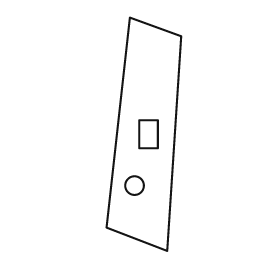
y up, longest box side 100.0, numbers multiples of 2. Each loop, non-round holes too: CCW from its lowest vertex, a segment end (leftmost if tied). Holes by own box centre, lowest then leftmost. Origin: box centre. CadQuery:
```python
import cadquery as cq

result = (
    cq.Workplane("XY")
    .moveTo(10.0, -50.0)
    .lineTo(16.0, 42.0)
    .lineTo(-6.0, 50.0)
    .lineTo(-16.0, -40.0)
    .close()
    .moveTo(-4.0, -22.0)
    .circle(4.0)
    .moveTo(-2.0, -6.0)
    .lineTo(6.0, -6.0)
    .lineTo(6.0, 6.0)
    .lineTo(-2.0, 6.0)
    .close()
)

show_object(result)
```